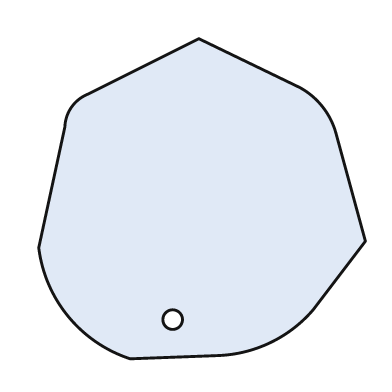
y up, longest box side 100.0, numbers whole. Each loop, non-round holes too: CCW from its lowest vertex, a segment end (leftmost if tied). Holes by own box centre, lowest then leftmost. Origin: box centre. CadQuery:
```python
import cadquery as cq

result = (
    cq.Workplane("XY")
    .moveTo(-22.0, -49.0)
    .lineTo(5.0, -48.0)
    .threePointArc((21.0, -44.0), (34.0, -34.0))
    .lineTo(50.0, -13.0)
    .lineTo(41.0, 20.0)
    .threePointArc((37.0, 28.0), (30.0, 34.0))
    .lineTo(-1.0, 49.0)
    .lineTo(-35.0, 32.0)
    .threePointArc((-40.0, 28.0), (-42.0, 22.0))
    .lineTo(-50.0, -15.0)
    .threePointArc((-41.0, -36.0), (-22.0, -49.0))
    .close()
    .moveTo(-9.0, -37.0)
    .circle(3.0)
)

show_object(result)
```